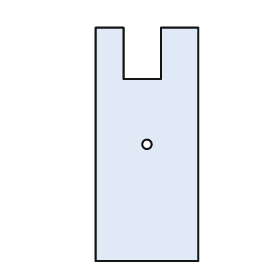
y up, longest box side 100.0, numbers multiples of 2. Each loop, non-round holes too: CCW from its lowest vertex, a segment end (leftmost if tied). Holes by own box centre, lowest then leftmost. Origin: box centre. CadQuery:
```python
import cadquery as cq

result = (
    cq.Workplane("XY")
    .moveTo(-22.0, -50.0)
    .lineTo(22.0, -50.0)
    .lineTo(22.0, 50.0)
    .lineTo(6.0, 50.0)
    .lineTo(6.0, 28.0)
    .lineTo(-10.0, 28.0)
    .lineTo(-10.0, 50.0)
    .lineTo(-22.0, 50.0)
    .close()
    .moveTo(0.0, 0.0)
    .circle(2.0)
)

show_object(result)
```